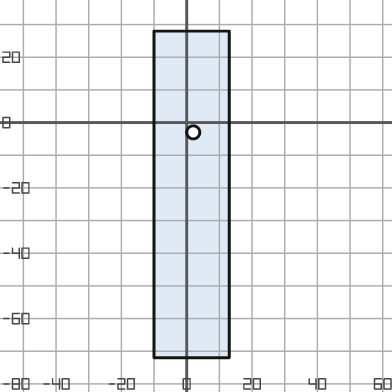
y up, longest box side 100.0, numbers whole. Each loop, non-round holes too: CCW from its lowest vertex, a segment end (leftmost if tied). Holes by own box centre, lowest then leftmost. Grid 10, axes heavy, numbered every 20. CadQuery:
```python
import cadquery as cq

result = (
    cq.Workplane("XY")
    .moveTo(-10.0, -72.0)
    .lineTo(13.0, -72.0)
    .lineTo(13.0, 28.0)
    .lineTo(-10.0, 28.0)
    .close()
    .moveTo(2.0, -3.0)
    .circle(2.0)
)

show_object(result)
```